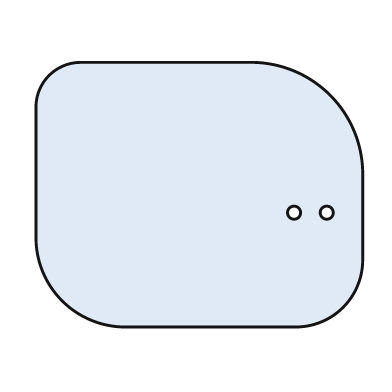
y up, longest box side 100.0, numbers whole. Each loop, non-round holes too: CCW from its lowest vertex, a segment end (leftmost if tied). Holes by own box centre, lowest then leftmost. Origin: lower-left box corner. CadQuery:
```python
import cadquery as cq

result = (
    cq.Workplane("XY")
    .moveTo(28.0, 0.0)
    .lineTo(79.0, 0.0)
    .threePointArc((94.0, 6.0), (100.0, 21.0))
    .lineTo(100.0, 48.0)
    .threePointArc((90.0, 71.0), (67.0, 81.0))
    .lineTo(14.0, 81.0)
    .threePointArc((4.0, 77.0), (0.0, 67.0))
    .lineTo(0.0, 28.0)
    .threePointArc((8.0, 8.0), (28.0, 0.0))
    .close()
    .moveTo(79.0, 35.0)
    .circle(2.0)
    .moveTo(89.0, 35.0)
    .circle(2.0)
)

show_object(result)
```